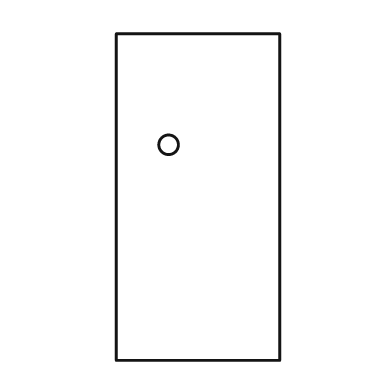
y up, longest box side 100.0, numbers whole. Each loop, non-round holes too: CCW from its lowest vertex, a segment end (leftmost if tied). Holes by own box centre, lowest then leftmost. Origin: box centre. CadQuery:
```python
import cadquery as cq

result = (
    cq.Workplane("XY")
    .moveTo(-25.0, -50.0)
    .lineTo(25.0, -50.0)
    .lineTo(25.0, 50.0)
    .lineTo(-25.0, 50.0)
    .close()
    .moveTo(-9.0, 16.0)
    .circle(3.0)
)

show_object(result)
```